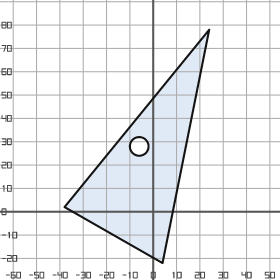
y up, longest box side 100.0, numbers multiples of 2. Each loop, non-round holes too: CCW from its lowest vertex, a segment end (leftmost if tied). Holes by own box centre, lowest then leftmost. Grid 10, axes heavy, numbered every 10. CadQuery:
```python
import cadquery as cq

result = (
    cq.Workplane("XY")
    .moveTo(4.0, -22.0)
    .lineTo(24.0, 78.0)
    .lineTo(-38.0, 2.0)
    .close()
    .moveTo(-6.0, 28.0)
    .circle(4.0)
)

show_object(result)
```